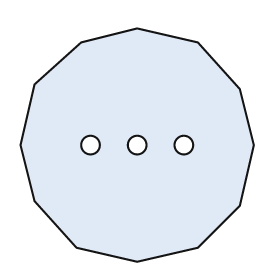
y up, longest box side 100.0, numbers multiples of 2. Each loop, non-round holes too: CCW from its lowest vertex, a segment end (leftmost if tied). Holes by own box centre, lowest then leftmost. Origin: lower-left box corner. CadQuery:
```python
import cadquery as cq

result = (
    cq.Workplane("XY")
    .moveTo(50.0, 0.0)
    .lineTo(76.0, 6.0)
    .lineTo(94.0, 24.0)
    .lineTo(100.0, 50.0)
    .lineTo(94.0, 74.0)
    .lineTo(76.0, 94.0)
    .lineTo(50.0, 100.0)
    .lineTo(26.0, 94.0)
    .lineTo(6.0, 76.0)
    .lineTo(0.0, 50.0)
    .lineTo(6.0, 26.0)
    .lineTo(24.0, 6.0)
    .close()
    .moveTo(30.0, 50.0)
    .circle(4.0)
    .moveTo(50.0, 50.0)
    .circle(4.0)
    .moveTo(70.0, 50.0)
    .circle(4.0)
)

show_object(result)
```